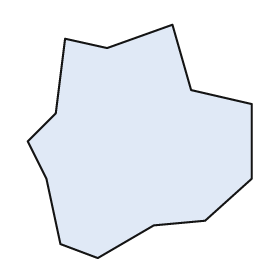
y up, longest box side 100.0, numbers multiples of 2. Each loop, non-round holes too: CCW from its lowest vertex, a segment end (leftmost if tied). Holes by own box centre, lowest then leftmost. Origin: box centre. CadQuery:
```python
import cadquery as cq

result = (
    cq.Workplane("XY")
    .moveTo(-18.0, -50.0)
    .lineTo(6.0, -36.0)
    .lineTo(28.0, -34.0)
    .lineTo(48.0, -16.0)
    .lineTo(48.0, 16.0)
    .lineTo(22.0, 22.0)
    .lineTo(14.0, 50.0)
    .lineTo(-14.0, 40.0)
    .lineTo(-32.0, 44.0)
    .lineTo(-36.0, 12.0)
    .lineTo(-48.0, 0.0)
    .lineTo(-40.0, -16.0)
    .lineTo(-34.0, -44.0)
    .close()
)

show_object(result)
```